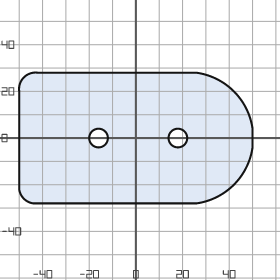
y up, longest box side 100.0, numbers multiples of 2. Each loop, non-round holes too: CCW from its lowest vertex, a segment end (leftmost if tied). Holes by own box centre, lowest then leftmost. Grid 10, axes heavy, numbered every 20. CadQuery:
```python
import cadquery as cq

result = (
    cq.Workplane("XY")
    .moveTo(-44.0, -28.0)
    .lineTo(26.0, -28.0)
    .threePointArc((42.0, -20.0), (50.0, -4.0))
    .lineTo(50.0, 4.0)
    .threePointArc((42.0, 20.0), (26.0, 28.0))
    .lineTo(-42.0, 28.0)
    .threePointArc((-48.0, 26.0), (-50.0, 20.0))
    .lineTo(-50.0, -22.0)
    .threePointArc((-48.0, -26.0), (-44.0, -28.0))
    .close()
    .moveTo(-16.0, 0.0)
    .circle(4.0)
    .moveTo(18.0, 0.0)
    .circle(4.0)
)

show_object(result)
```